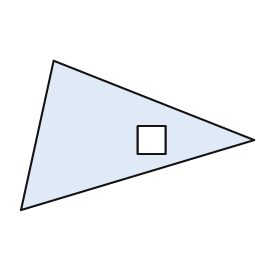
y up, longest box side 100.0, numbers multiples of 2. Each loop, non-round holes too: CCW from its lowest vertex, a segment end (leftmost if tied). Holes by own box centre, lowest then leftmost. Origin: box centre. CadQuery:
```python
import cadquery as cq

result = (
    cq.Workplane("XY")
    .moveTo(-50.0, -32.0)
    .lineTo(50.0, -2.0)
    .lineTo(-36.0, 32.0)
    .close()
    .moveTo(0.0, -8.0)
    .lineTo(12.0, -8.0)
    .lineTo(12.0, 4.0)
    .lineTo(0.0, 4.0)
    .close()
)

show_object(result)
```